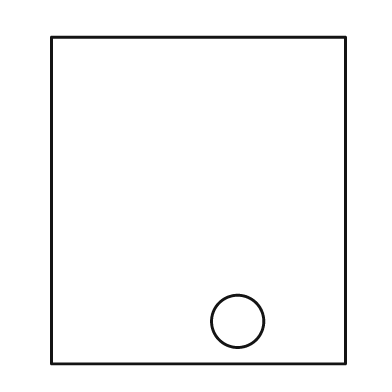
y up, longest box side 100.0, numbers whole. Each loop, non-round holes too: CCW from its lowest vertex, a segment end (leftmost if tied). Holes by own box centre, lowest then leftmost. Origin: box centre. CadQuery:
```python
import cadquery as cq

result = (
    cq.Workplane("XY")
    .moveTo(-45.0, -50.0)
    .lineTo(45.0, -50.0)
    .lineTo(45.0, 50.0)
    .lineTo(-45.0, 50.0)
    .close()
    .moveTo(12.0, -37.0)
    .circle(8.0)
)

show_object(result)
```